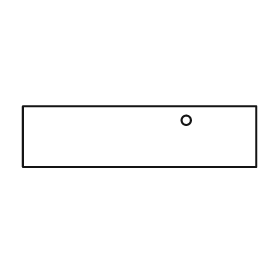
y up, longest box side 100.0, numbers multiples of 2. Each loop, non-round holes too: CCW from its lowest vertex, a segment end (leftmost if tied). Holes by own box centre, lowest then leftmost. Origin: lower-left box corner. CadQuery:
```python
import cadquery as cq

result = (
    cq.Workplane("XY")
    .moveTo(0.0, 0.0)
    .lineTo(100.0, 0.0)
    .lineTo(100.0, 26.0)
    .lineTo(0.0, 26.0)
    .close()
    .moveTo(70.0, 20.0)
    .circle(2.0)
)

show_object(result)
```